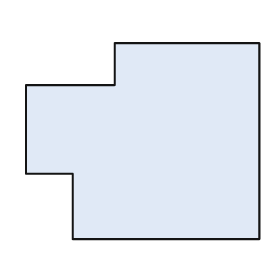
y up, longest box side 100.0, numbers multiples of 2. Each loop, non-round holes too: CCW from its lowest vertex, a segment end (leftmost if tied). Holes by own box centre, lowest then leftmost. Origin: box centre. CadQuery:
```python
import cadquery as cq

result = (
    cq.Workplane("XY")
    .moveTo(-30.0, -42.0)
    .lineTo(50.0, -42.0)
    .lineTo(50.0, 42.0)
    .lineTo(-12.0, 42.0)
    .lineTo(-12.0, 24.0)
    .lineTo(-50.0, 24.0)
    .lineTo(-50.0, -14.0)
    .lineTo(-30.0, -14.0)
    .close()
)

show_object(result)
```